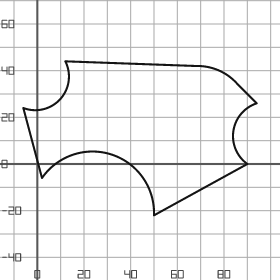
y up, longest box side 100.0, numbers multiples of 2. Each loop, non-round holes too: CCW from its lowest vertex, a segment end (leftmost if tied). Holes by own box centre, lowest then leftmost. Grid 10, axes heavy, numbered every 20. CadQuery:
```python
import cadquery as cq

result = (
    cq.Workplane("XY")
    .moveTo(50.0, -22.0)
    .lineTo(90.0, 0.0)
    .threePointArc((84.0, 14.0), (94.0, 26.0))
    .lineTo(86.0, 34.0)
    .threePointArc((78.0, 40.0), (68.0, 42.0))
    .lineTo(12.0, 44.0)
    .threePointArc((10.0, 28.0), (-6.0, 24.0))
    .lineTo(2.0, -6.0)
    .threePointArc((32.0, 4.0), (50.0, -22.0))
    .close()
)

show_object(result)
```